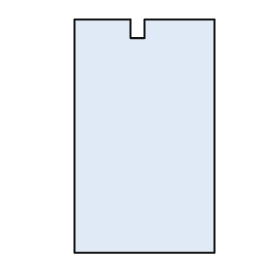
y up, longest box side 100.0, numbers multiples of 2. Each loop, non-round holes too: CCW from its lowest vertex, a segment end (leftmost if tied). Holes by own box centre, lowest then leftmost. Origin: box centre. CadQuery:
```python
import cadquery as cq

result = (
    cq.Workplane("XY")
    .moveTo(-30.0, -50.0)
    .lineTo(30.0, -50.0)
    .lineTo(30.0, 50.0)
    .lineTo(0.0, 50.0)
    .lineTo(0.0, 42.0)
    .lineTo(-6.0, 42.0)
    .lineTo(-6.0, 50.0)
    .lineTo(-30.0, 50.0)
    .close()
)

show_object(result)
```